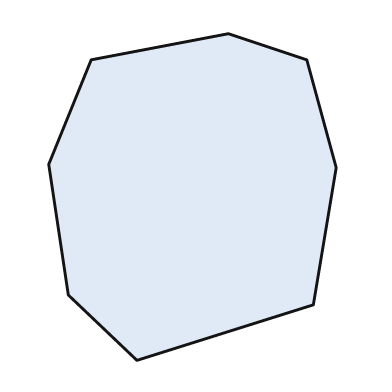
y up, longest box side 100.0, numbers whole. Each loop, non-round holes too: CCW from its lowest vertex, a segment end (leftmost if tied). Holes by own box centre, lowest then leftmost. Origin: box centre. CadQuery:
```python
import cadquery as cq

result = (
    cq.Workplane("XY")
    .moveTo(-17.0, -50.0)
    .lineTo(37.0, -33.0)
    .lineTo(44.0, 9.0)
    .lineTo(35.0, 42.0)
    .lineTo(11.0, 50.0)
    .lineTo(-31.0, 42.0)
    .lineTo(-44.0, 10.0)
    .lineTo(-38.0, -30.0)
    .close()
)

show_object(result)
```